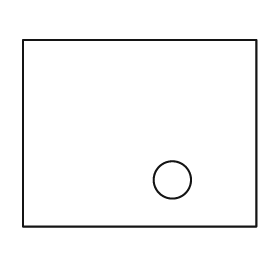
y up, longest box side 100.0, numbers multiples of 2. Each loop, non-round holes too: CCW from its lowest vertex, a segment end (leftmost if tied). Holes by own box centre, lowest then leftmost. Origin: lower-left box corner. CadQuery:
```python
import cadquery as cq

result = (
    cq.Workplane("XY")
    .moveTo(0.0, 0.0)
    .lineTo(100.0, 0.0)
    .lineTo(100.0, 80.0)
    .lineTo(0.0, 80.0)
    .close()
    .moveTo(64.0, 20.0)
    .circle(8.0)
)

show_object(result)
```